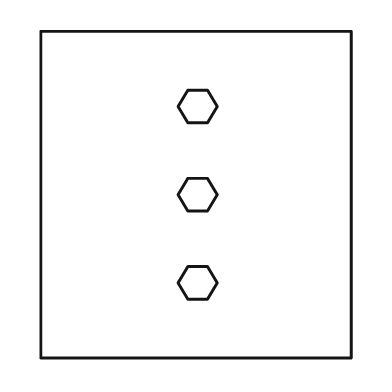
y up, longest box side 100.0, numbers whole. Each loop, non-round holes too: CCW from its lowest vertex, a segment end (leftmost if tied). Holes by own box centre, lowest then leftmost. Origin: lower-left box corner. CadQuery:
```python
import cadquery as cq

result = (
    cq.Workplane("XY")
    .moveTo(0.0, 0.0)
    .lineTo(95.0, 0.0)
    .lineTo(95.0, 100.0)
    .lineTo(0.0, 100.0)
    .close()
    .moveTo(45.0, 18.0)
    .lineTo(51.0, 18.0)
    .lineTo(54.0, 23.0)
    .lineTo(51.0, 28.0)
    .lineTo(45.0, 28.0)
    .lineTo(42.0, 23.0)
    .close()
    .moveTo(45.0, 45.0)
    .lineTo(51.0, 45.0)
    .lineTo(54.0, 50.0)
    .lineTo(51.0, 55.0)
    .lineTo(45.0, 55.0)
    .lineTo(42.0, 50.0)
    .close()
    .moveTo(45.0, 72.0)
    .lineTo(51.0, 72.0)
    .lineTo(54.0, 77.0)
    .lineTo(51.0, 82.0)
    .lineTo(45.0, 82.0)
    .lineTo(42.0, 77.0)
    .close()
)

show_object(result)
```